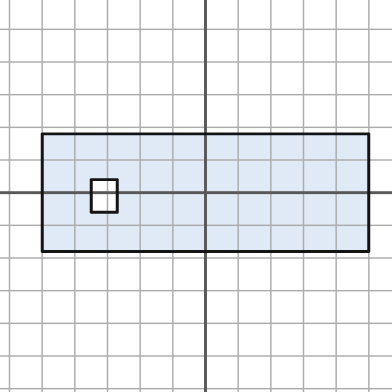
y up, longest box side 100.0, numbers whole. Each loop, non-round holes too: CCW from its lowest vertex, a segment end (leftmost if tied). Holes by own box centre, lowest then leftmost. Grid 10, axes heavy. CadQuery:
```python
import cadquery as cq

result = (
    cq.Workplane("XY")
    .moveTo(-50.0, -18.0)
    .lineTo(50.0, -18.0)
    .lineTo(50.0, 18.0)
    .lineTo(-50.0, 18.0)
    .close()
    .moveTo(-35.0, -6.0)
    .lineTo(-27.0, -6.0)
    .lineTo(-27.0, 4.0)
    .lineTo(-35.0, 4.0)
    .close()
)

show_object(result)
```